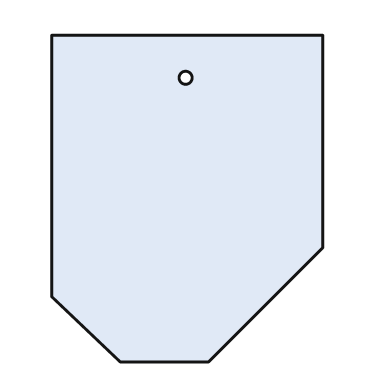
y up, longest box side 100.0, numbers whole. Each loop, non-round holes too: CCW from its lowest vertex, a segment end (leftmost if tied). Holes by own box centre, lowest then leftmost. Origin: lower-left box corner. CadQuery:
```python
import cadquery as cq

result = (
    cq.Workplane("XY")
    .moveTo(21.0, 0.0)
    .lineTo(48.0, 0.0)
    .lineTo(83.0, 35.0)
    .lineTo(83.0, 100.0)
    .lineTo(0.0, 100.0)
    .lineTo(0.0, 20.0)
    .close()
    .moveTo(41.0, 87.0)
    .circle(2.0)
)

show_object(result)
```